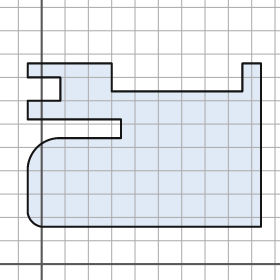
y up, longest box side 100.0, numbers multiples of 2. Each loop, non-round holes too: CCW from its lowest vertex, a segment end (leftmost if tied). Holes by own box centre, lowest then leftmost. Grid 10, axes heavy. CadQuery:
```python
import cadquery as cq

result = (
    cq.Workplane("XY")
    .moveTo(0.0, 16.0)
    .lineTo(94.0, 16.0)
    .lineTo(94.0, 86.0)
    .lineTo(86.0, 86.0)
    .lineTo(86.0, 74.0)
    .lineTo(30.0, 74.0)
    .lineTo(30.0, 86.0)
    .lineTo(-6.0, 86.0)
    .lineTo(-6.0, 80.0)
    .lineTo(8.0, 80.0)
    .lineTo(8.0, 70.0)
    .lineTo(-6.0, 70.0)
    .lineTo(-6.0, 62.0)
    .lineTo(34.0, 62.0)
    .lineTo(34.0, 54.0)
    .lineTo(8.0, 54.0)
    .threePointArc((-2.0, 50.0), (-6.0, 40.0))
    .lineTo(-6.0, 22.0)
    .threePointArc((-4.0, 18.0), (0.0, 16.0))
    .close()
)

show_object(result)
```